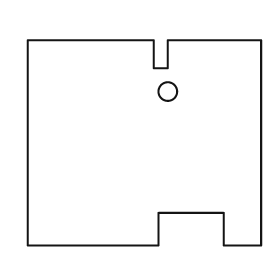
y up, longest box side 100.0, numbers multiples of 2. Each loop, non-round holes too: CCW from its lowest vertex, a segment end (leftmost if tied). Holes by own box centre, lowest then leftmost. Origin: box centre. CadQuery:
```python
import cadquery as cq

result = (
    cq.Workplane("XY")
    .moveTo(-50.0, -44.0)
    .lineTo(6.0, -44.0)
    .lineTo(6.0, -30.0)
    .lineTo(34.0, -30.0)
    .lineTo(34.0, -44.0)
    .lineTo(50.0, -44.0)
    .lineTo(50.0, 44.0)
    .lineTo(10.0, 44.0)
    .lineTo(10.0, 32.0)
    .lineTo(4.0, 32.0)
    .lineTo(4.0, 44.0)
    .lineTo(-50.0, 44.0)
    .close()
    .moveTo(10.0, 22.0)
    .circle(4.0)
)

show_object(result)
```